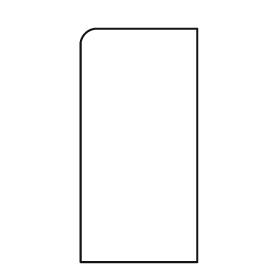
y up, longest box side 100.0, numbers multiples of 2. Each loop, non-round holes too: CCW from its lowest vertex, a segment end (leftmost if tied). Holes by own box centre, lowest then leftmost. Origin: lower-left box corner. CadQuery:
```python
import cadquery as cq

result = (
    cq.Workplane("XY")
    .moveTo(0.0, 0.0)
    .lineTo(50.0, 0.0)
    .lineTo(50.0, 100.0)
    .lineTo(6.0, 100.0)
    .threePointArc((2.0, 98.0), (0.0, 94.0))
    .close()
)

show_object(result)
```